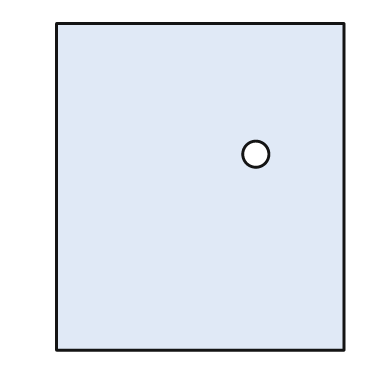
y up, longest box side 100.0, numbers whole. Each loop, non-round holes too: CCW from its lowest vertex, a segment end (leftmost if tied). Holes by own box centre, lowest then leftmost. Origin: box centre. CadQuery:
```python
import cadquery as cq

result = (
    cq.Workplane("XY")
    .moveTo(-44.0, -50.0)
    .lineTo(44.0, -50.0)
    .lineTo(44.0, 50.0)
    .lineTo(-44.0, 50.0)
    .close()
    .moveTo(17.0, 10.0)
    .circle(4.0)
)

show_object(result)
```